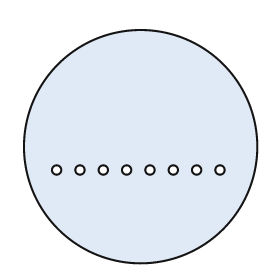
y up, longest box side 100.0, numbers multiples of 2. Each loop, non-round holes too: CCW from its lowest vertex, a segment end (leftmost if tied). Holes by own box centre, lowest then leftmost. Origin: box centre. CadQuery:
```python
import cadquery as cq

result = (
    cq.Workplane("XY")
    .moveTo(0.0, 0.0)
    .circle(50.0)
    .moveTo(-36.0, -10.0)
    .circle(2.0)
    .moveTo(-26.0, -10.0)
    .circle(2.0)
    .moveTo(-16.0, -10.0)
    .circle(2.0)
    .moveTo(-6.0, -10.0)
    .circle(2.0)
    .moveTo(4.0, -10.0)
    .circle(2.0)
    .moveTo(14.0, -10.0)
    .circle(2.0)
    .moveTo(24.0, -10.0)
    .circle(2.0)
    .moveTo(34.0, -10.0)
    .circle(2.0)
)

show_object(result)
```